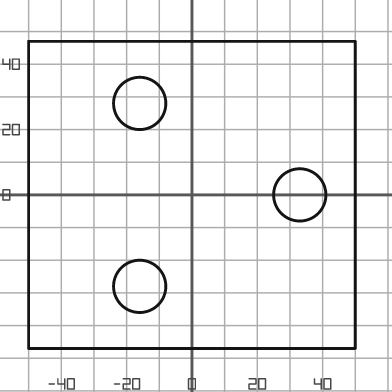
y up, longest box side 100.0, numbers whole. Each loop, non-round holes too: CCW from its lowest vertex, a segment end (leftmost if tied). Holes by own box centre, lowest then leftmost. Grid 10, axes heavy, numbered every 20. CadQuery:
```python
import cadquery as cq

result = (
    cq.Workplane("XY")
    .moveTo(-50.0, -47.0)
    .lineTo(50.0, -47.0)
    .lineTo(50.0, 47.0)
    .lineTo(-50.0, 47.0)
    .close()
    .moveTo(-16.0, -28.0)
    .circle(8.0)
    .moveTo(33.0, 0.0)
    .circle(8.0)
    .moveTo(-16.0, 28.0)
    .circle(8.0)
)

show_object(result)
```